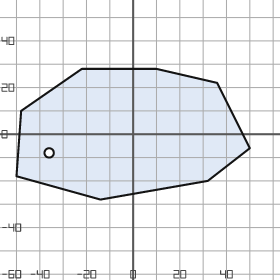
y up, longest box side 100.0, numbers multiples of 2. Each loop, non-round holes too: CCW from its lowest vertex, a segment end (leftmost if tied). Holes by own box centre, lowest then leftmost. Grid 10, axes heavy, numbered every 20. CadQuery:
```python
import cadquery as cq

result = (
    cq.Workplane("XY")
    .moveTo(-14.0, -28.0)
    .lineTo(32.0, -20.0)
    .lineTo(50.0, -6.0)
    .lineTo(36.0, 22.0)
    .lineTo(10.0, 28.0)
    .lineTo(-22.0, 28.0)
    .lineTo(-48.0, 10.0)
    .lineTo(-50.0, -18.0)
    .close()
    .moveTo(-36.0, -8.0)
    .circle(2.0)
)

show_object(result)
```